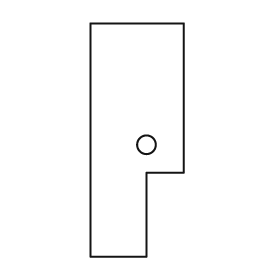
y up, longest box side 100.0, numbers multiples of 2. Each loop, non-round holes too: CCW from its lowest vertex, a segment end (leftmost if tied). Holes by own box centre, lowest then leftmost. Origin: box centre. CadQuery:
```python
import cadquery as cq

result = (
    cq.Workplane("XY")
    .moveTo(-20.0, -50.0)
    .lineTo(4.0, -50.0)
    .lineTo(4.0, -14.0)
    .lineTo(20.0, -14.0)
    .lineTo(20.0, 50.0)
    .lineTo(-20.0, 50.0)
    .close()
    .moveTo(4.0, -2.0)
    .circle(4.0)
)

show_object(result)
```